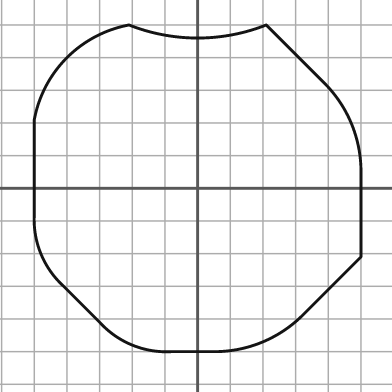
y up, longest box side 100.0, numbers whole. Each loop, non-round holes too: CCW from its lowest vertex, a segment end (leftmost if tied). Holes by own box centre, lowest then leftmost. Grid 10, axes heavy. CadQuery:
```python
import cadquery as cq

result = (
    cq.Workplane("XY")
    .moveTo(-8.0, -50.0)
    .lineTo(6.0, -50.0)
    .threePointArc((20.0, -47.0), (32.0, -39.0))
    .lineTo(50.0, -21.0)
    .lineTo(50.0, 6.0)
    .threePointArc((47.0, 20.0), (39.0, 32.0))
    .lineTo(21.0, 50.0)
    .threePointArc((0.0, 46.0), (-21.0, 50.0))
    .threePointArc((-40.0, 40.0), (-50.0, 21.0))
    .lineTo(-50.0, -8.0)
    .threePointArc((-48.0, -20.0), (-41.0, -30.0))
    .lineTo(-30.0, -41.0)
    .threePointArc((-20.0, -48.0), (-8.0, -50.0))
    .close()
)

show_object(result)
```